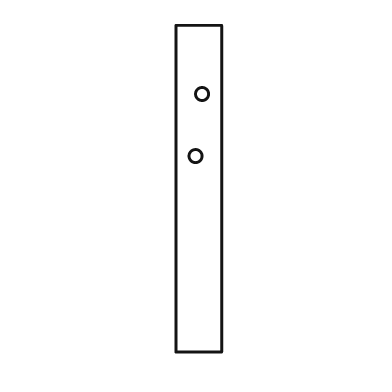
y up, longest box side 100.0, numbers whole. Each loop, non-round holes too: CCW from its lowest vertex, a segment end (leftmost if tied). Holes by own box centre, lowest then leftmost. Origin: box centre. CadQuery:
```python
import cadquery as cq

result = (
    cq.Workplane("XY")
    .moveTo(-7.0, -50.0)
    .lineTo(7.0, -50.0)
    .lineTo(7.0, 50.0)
    .lineTo(-7.0, 50.0)
    .close()
    .moveTo(-1.0, 10.0)
    .circle(2.0)
    .moveTo(1.0, 29.0)
    .circle(2.0)
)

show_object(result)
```